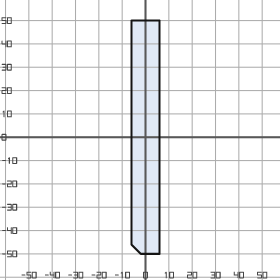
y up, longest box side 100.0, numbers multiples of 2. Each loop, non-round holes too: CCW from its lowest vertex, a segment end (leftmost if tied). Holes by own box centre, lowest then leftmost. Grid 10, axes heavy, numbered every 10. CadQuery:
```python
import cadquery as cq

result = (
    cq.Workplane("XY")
    .moveTo(-2.0, -50.0)
    .lineTo(6.0, -50.0)
    .lineTo(6.0, 50.0)
    .lineTo(-6.0, 50.0)
    .lineTo(-6.0, -46.0)
    .close()
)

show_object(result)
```